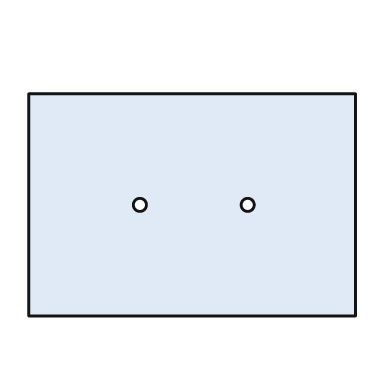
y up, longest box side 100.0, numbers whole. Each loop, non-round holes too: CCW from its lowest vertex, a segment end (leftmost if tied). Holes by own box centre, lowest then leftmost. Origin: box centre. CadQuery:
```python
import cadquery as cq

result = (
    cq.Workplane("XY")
    .moveTo(-50.0, -34.0)
    .lineTo(50.0, -34.0)
    .lineTo(50.0, 34.0)
    .lineTo(-50.0, 34.0)
    .close()
    .moveTo(-16.0, 0.0)
    .circle(2.0)
    .moveTo(17.0, 0.0)
    .circle(2.0)
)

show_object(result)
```